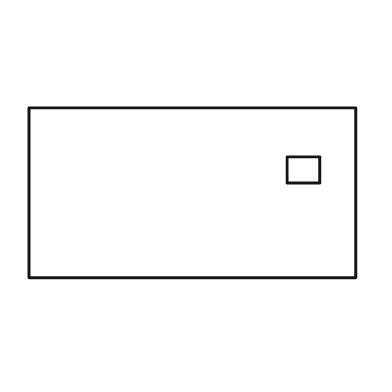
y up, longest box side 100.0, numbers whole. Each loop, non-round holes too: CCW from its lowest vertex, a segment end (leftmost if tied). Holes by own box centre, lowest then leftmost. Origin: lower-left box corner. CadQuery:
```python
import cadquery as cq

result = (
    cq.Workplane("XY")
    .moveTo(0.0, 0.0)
    .lineTo(100.0, 0.0)
    .lineTo(100.0, 52.0)
    .lineTo(0.0, 52.0)
    .close()
    .moveTo(79.0, 29.0)
    .lineTo(89.0, 29.0)
    .lineTo(89.0, 37.0)
    .lineTo(79.0, 37.0)
    .close()
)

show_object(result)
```